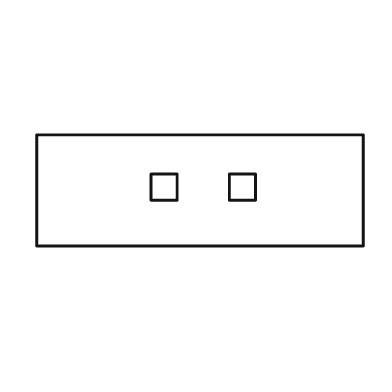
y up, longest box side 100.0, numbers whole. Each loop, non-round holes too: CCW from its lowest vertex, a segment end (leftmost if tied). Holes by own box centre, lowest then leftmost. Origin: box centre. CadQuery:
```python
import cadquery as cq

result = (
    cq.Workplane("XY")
    .moveTo(-50.0, -17.0)
    .lineTo(50.0, -17.0)
    .lineTo(50.0, 17.0)
    .lineTo(-50.0, 17.0)
    .close()
    .moveTo(-15.0, -3.0)
    .lineTo(-7.0, -3.0)
    .lineTo(-7.0, 5.0)
    .lineTo(-15.0, 5.0)
    .close()
    .moveTo(9.0, -3.0)
    .lineTo(17.0, -3.0)
    .lineTo(17.0, 5.0)
    .lineTo(9.0, 5.0)
    .close()
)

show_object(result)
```